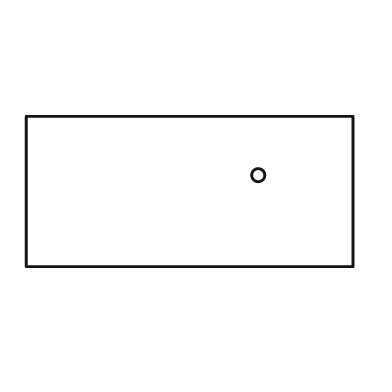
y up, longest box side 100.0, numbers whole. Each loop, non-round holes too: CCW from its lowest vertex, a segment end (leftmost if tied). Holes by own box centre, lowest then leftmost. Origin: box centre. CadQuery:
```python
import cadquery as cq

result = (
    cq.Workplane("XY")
    .moveTo(-50.0, -23.0)
    .lineTo(50.0, -23.0)
    .lineTo(50.0, 23.0)
    .lineTo(-50.0, 23.0)
    .close()
    .moveTo(21.0, 5.0)
    .circle(2.0)
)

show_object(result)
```